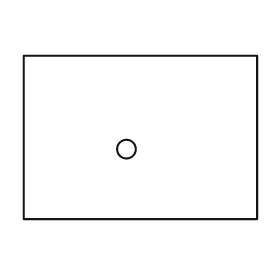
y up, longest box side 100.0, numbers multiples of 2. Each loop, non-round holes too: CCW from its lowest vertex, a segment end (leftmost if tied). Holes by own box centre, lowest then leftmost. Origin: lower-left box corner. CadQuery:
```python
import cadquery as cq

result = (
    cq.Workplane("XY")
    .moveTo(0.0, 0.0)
    .lineTo(100.0, 0.0)
    .lineTo(100.0, 70.0)
    .lineTo(0.0, 70.0)
    .close()
    .moveTo(44.0, 30.0)
    .circle(4.0)
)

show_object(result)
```